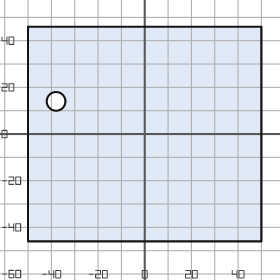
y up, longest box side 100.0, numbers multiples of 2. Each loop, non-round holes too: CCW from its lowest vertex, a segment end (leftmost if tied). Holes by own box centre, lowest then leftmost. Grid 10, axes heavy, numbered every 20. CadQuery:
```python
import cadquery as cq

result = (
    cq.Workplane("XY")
    .moveTo(-50.0, -46.0)
    .lineTo(50.0, -46.0)
    .lineTo(50.0, 46.0)
    .lineTo(-50.0, 46.0)
    .close()
    .moveTo(-38.0, 14.0)
    .circle(4.0)
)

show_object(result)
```